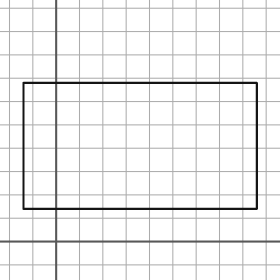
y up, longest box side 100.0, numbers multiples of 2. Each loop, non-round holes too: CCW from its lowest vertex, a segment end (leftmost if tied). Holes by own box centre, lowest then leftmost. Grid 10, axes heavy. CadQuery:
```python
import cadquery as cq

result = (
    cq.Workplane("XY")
    .moveTo(-14.0, 14.0)
    .lineTo(86.0, 14.0)
    .lineTo(86.0, 68.0)
    .lineTo(-14.0, 68.0)
    .close()
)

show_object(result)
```